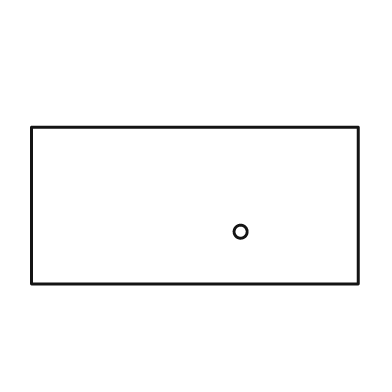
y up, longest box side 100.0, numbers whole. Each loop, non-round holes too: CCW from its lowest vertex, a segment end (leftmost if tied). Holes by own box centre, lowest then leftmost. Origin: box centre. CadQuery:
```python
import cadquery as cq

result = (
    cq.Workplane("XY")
    .moveTo(-50.0, -24.0)
    .lineTo(50.0, -24.0)
    .lineTo(50.0, 24.0)
    .lineTo(-50.0, 24.0)
    .close()
    .moveTo(14.0, -8.0)
    .circle(2.0)
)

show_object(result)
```